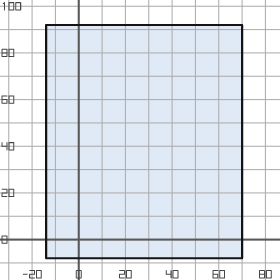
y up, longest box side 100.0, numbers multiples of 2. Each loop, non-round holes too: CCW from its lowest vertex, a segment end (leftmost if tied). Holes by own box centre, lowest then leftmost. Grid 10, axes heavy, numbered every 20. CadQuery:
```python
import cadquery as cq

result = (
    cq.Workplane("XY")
    .moveTo(-14.0, -8.0)
    .lineTo(70.0, -8.0)
    .lineTo(70.0, 92.0)
    .lineTo(-14.0, 92.0)
    .close()
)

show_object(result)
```